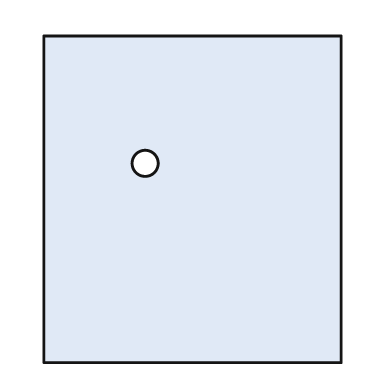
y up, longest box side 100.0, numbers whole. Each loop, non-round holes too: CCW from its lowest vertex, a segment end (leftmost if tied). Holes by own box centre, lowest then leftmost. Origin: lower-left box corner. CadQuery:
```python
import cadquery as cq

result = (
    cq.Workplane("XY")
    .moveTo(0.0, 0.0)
    .lineTo(91.0, 0.0)
    .lineTo(91.0, 100.0)
    .lineTo(0.0, 100.0)
    .close()
    .moveTo(31.0, 61.0)
    .circle(4.0)
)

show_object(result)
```